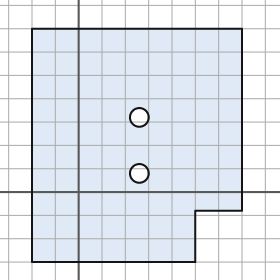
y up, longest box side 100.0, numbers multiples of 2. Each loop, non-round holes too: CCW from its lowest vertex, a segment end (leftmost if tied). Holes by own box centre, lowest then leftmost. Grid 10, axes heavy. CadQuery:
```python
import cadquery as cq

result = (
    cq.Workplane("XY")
    .moveTo(-20.0, -30.0)
    .lineTo(50.0, -30.0)
    .lineTo(50.0, -8.0)
    .lineTo(70.0, -8.0)
    .lineTo(70.0, 70.0)
    .lineTo(-20.0, 70.0)
    .close()
    .moveTo(26.0, 8.0)
    .circle(4.0)
    .moveTo(26.0, 32.0)
    .circle(4.0)
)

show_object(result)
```